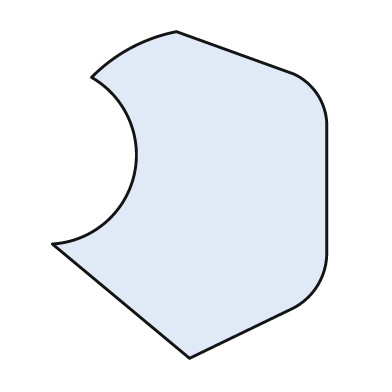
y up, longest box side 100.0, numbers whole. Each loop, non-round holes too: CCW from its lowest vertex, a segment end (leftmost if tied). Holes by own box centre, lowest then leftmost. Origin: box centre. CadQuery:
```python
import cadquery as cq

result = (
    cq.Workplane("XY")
    .moveTo(0.0, -50.0)
    .lineTo(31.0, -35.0)
    .threePointArc((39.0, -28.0), (42.0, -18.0))
    .lineTo(42.0, 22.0)
    .threePointArc((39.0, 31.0), (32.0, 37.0))
    .lineTo(-4.0, 50.0)
    .threePointArc((-18.0, 45.0), (-30.0, 36.0))
    .threePointArc((-17.0, 6.0), (-42.0, -15.0))
    .close()
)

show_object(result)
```